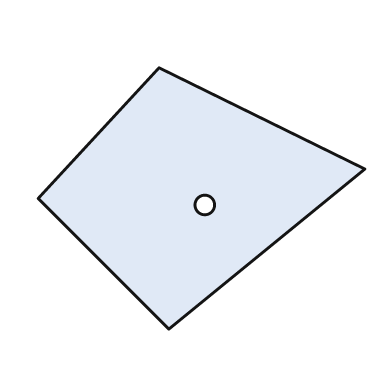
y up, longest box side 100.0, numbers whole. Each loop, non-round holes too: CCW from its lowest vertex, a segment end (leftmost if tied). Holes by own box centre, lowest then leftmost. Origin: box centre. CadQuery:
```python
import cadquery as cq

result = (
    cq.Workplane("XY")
    .moveTo(-10.0, -40.0)
    .lineTo(50.0, 9.0)
    .lineTo(-13.0, 40.0)
    .lineTo(-50.0, 0.0)
    .close()
    .moveTo(1.0, -2.0)
    .circle(3.0)
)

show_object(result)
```